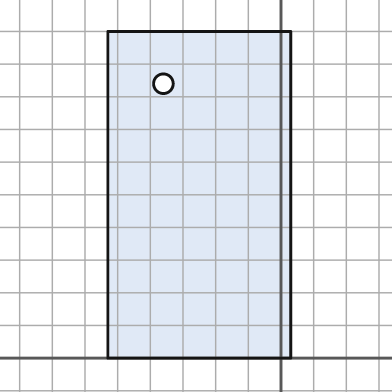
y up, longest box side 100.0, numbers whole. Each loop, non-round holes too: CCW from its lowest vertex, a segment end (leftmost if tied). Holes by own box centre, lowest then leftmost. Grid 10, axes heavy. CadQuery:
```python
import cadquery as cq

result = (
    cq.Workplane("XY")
    .moveTo(-53.0, 0.0)
    .lineTo(3.0, 0.0)
    .lineTo(3.0, 100.0)
    .lineTo(-53.0, 100.0)
    .close()
    .moveTo(-36.0, 84.0)
    .circle(3.0)
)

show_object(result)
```